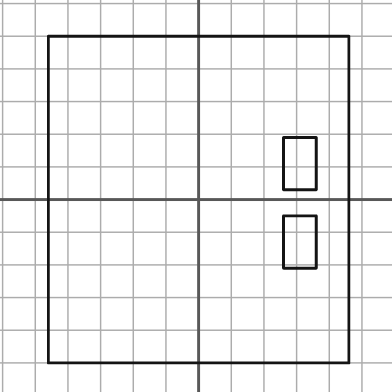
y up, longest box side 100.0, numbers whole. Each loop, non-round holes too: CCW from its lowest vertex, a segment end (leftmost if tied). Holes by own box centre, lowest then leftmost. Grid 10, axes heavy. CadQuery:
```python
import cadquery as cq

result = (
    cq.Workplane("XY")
    .moveTo(-46.0, -50.0)
    .lineTo(46.0, -50.0)
    .lineTo(46.0, 50.0)
    .lineTo(-46.0, 50.0)
    .close()
    .moveTo(26.0, -21.0)
    .lineTo(36.0, -21.0)
    .lineTo(36.0, -5.0)
    .lineTo(26.0, -5.0)
    .close()
    .moveTo(26.0, 3.0)
    .lineTo(36.0, 3.0)
    .lineTo(36.0, 19.0)
    .lineTo(26.0, 19.0)
    .close()
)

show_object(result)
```